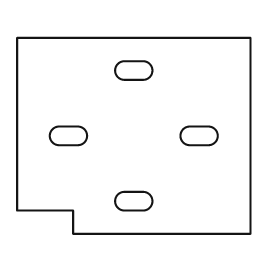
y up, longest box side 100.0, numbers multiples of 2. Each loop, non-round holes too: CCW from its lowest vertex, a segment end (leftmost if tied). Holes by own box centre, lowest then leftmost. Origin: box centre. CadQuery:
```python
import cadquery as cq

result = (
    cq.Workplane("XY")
    .moveTo(-26.0, -42.0)
    .lineTo(50.0, -42.0)
    .lineTo(50.0, 42.0)
    .lineTo(-50.0, 42.0)
    .lineTo(-50.0, -32.0)
    .lineTo(-26.0, -32.0)
    .close()
    .moveTo(-4.0, -32.0)
    .lineTo(4.0, -32.0)
    .threePointArc((8.0, -28.0), (4.0, -24.0))
    .lineTo(-4.0, -24.0)
    .threePointArc((-8.0, -28.0), (-4.0, -32.0))
    .close()
    .moveTo(-32.0, -4.0)
    .lineTo(-24.0, -4.0)
    .threePointArc((-20.0, 0.0), (-24.0, 4.0))
    .lineTo(-32.0, 4.0)
    .threePointArc((-36.0, 0.0), (-32.0, -4.0))
    .close()
    .moveTo(24.0, -4.0)
    .lineTo(32.0, -4.0)
    .threePointArc((36.0, 0.0), (32.0, 4.0))
    .lineTo(24.0, 4.0)
    .threePointArc((20.0, 0.0), (24.0, -4.0))
    .close()
    .moveTo(-4.0, 24.0)
    .lineTo(4.0, 24.0)
    .threePointArc((8.0, 28.0), (4.0, 32.0))
    .lineTo(-4.0, 32.0)
    .threePointArc((-8.0, 28.0), (-4.0, 24.0))
    .close()
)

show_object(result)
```